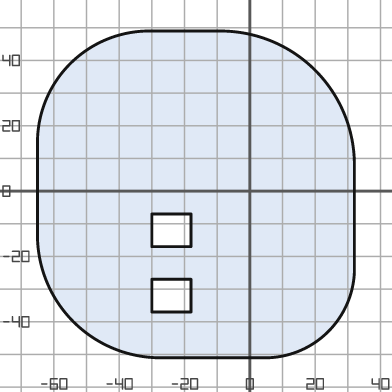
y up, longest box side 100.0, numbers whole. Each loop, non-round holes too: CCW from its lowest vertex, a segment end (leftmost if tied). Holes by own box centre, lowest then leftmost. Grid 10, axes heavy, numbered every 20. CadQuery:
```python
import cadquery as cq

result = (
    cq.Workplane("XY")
    .moveTo(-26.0, -51.0)
    .lineTo(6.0, -51.0)
    .threePointArc((24.0, -43.0), (32.0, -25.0))
    .lineTo(32.0, 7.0)
    .threePointArc((20.0, 37.0), (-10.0, 49.0))
    .lineTo(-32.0, 49.0)
    .threePointArc((-55.0, 39.0), (-65.0, 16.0))
    .lineTo(-65.0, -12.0)
    .threePointArc((-54.0, -40.0), (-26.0, -51.0))
    .close()
    .moveTo(-30.0, -37.0)
    .lineTo(-18.0, -37.0)
    .lineTo(-18.0, -27.0)
    .lineTo(-30.0, -27.0)
    .close()
    .moveTo(-30.0, -17.0)
    .lineTo(-18.0, -17.0)
    .lineTo(-18.0, -7.0)
    .lineTo(-30.0, -7.0)
    .close()
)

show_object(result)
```